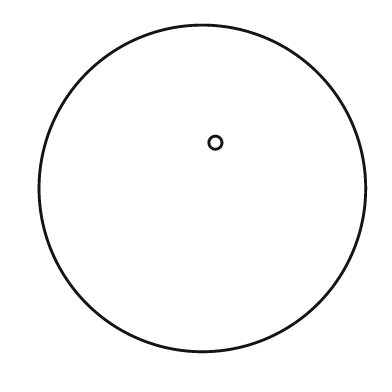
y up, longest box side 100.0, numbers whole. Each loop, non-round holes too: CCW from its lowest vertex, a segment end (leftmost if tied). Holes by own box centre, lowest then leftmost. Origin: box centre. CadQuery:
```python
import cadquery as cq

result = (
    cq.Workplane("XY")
    .moveTo(0.0, 0.0)
    .circle(50.0)
    .moveTo(4.0, 14.0)
    .circle(2.0)
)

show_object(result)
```